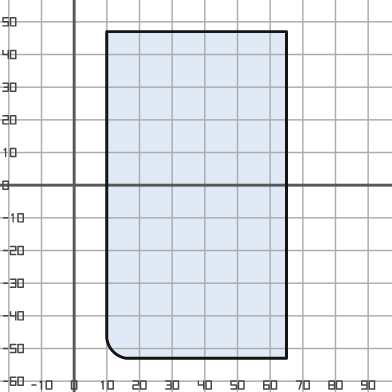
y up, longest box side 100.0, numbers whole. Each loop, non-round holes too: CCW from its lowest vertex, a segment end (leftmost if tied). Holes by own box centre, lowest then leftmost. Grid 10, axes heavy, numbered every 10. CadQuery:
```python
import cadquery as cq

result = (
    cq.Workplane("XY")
    .moveTo(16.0, -53.0)
    .lineTo(65.0, -53.0)
    .lineTo(65.0, 47.0)
    .lineTo(10.0, 47.0)
    .lineTo(10.0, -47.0)
    .threePointArc((12.0, -51.0), (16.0, -53.0))
    .close()
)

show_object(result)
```